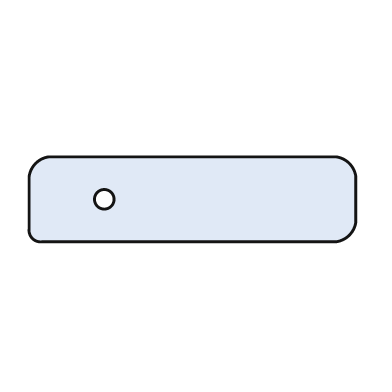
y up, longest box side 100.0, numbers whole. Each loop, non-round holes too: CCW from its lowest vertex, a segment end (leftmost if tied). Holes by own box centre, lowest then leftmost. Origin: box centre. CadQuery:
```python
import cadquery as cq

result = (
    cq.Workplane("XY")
    .moveTo(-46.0, -13.0)
    .lineTo(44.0, -13.0)
    .threePointArc((48.0, -11.0), (50.0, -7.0))
    .lineTo(50.0, 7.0)
    .threePointArc((48.0, 11.0), (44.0, 13.0))
    .lineTo(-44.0, 13.0)
    .threePointArc((-48.0, 11.0), (-50.0, 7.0))
    .lineTo(-50.0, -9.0)
    .threePointArc((-49.0, -12.0), (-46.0, -13.0))
    .close()
    .moveTo(-27.0, 0.0)
    .circle(3.0)
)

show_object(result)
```